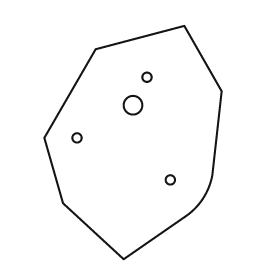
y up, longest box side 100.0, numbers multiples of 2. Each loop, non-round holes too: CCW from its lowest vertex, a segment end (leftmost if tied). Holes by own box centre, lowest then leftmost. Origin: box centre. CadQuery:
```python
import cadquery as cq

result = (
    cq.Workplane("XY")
    .moveTo(-4.0, -50.0)
    .lineTo(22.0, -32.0)
    .threePointArc((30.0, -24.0), (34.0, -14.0))
    .lineTo(38.0, 22.0)
    .lineTo(22.0, 50.0)
    .lineTo(-16.0, 40.0)
    .lineTo(-38.0, 2.0)
    .lineTo(-30.0, -26.0)
    .close()
    .moveTo(16.0, -16.0)
    .circle(2.0)
    .moveTo(-24.0, 2.0)
    .circle(2.0)
    .moveTo(0.0, 16.0)
    .circle(4.0)
    .moveTo(6.0, 28.0)
    .circle(2.0)
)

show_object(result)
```